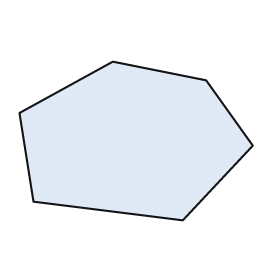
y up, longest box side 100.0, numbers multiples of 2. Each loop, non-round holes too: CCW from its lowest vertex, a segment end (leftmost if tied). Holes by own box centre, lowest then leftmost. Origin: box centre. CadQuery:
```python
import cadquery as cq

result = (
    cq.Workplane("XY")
    .moveTo(20.0, -34.0)
    .lineTo(50.0, -2.0)
    .lineTo(30.0, 26.0)
    .lineTo(-10.0, 34.0)
    .lineTo(-50.0, 12.0)
    .lineTo(-44.0, -26.0)
    .close()
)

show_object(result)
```